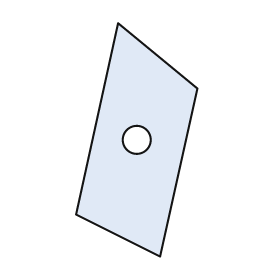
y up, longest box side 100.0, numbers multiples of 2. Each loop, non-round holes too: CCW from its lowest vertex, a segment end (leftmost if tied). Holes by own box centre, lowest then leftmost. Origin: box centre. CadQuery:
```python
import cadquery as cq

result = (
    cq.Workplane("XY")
    .moveTo(10.0, -50.0)
    .lineTo(26.0, 22.0)
    .lineTo(-8.0, 50.0)
    .lineTo(-26.0, -32.0)
    .close()
    .moveTo(0.0, 0.0)
    .circle(6.0)
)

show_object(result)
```